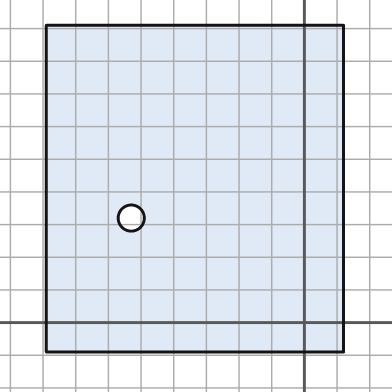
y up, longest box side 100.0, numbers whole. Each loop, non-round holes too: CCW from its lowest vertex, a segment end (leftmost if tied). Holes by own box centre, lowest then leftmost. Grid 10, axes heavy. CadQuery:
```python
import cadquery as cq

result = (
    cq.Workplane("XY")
    .moveTo(-79.0, -9.0)
    .lineTo(12.0, -9.0)
    .lineTo(12.0, 91.0)
    .lineTo(-79.0, 91.0)
    .close()
    .moveTo(-53.0, 32.0)
    .circle(4.0)
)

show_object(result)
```